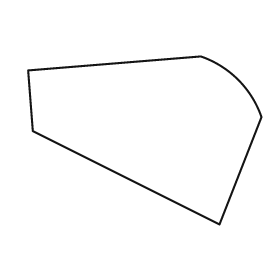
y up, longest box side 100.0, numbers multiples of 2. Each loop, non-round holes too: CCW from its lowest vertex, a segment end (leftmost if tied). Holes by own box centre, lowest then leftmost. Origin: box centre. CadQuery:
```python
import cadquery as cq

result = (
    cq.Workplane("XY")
    .moveTo(32.0, -36.0)
    .lineTo(50.0, 10.0)
    .threePointArc((40.0, 26.0), (24.0, 36.0))
    .lineTo(-50.0, 30.0)
    .lineTo(-48.0, 4.0)
    .close()
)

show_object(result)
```